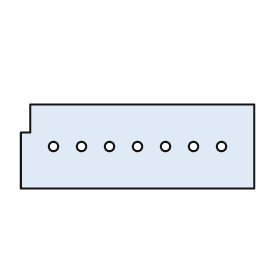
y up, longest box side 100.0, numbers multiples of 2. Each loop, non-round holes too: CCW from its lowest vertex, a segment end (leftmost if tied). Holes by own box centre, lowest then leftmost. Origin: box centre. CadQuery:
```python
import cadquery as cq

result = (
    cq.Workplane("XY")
    .moveTo(-50.0, -18.0)
    .lineTo(50.0, -18.0)
    .lineTo(50.0, 18.0)
    .lineTo(-46.0, 18.0)
    .lineTo(-46.0, 6.0)
    .lineTo(-50.0, 6.0)
    .close()
    .moveTo(-36.0, 0.0)
    .circle(2.0)
    .moveTo(-24.0, 0.0)
    .circle(2.0)
    .moveTo(-12.0, 0.0)
    .circle(2.0)
    .moveTo(0.0, 0.0)
    .circle(2.0)
    .moveTo(12.0, 0.0)
    .circle(2.0)
    .moveTo(24.0, 0.0)
    .circle(2.0)
    .moveTo(36.0, 0.0)
    .circle(2.0)
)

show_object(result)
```